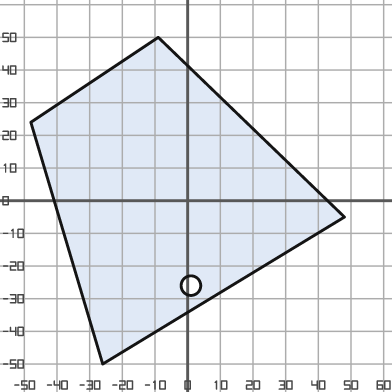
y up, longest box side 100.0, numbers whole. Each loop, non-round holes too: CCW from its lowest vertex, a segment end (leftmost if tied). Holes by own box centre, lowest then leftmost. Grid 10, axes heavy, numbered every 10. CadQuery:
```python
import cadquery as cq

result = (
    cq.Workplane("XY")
    .moveTo(-26.0, -50.0)
    .lineTo(48.0, -5.0)
    .lineTo(-9.0, 50.0)
    .lineTo(-48.0, 24.0)
    .close()
    .moveTo(1.0, -26.0)
    .circle(3.0)
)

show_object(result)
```